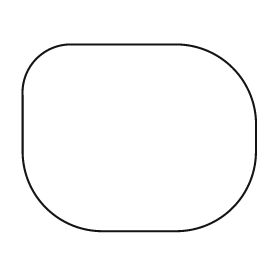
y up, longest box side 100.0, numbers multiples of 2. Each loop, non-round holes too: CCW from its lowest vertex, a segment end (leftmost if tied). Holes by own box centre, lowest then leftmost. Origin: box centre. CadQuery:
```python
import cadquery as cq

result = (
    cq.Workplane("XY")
    .moveTo(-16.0, -40.0)
    .lineTo(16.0, -40.0)
    .threePointArc((40.0, -30.0), (50.0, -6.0))
    .lineTo(50.0, 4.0)
    .threePointArc((40.0, 30.0), (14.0, 40.0))
    .lineTo(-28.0, 40.0)
    .threePointArc((-44.0, 34.0), (-50.0, 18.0))
    .lineTo(-50.0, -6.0)
    .threePointArc((-40.0, -30.0), (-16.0, -40.0))
    .close()
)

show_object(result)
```